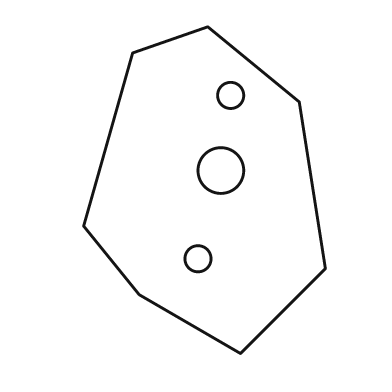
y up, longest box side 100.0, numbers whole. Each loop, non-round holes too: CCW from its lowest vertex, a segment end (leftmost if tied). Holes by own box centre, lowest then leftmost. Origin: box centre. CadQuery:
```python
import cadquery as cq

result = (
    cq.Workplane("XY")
    .moveTo(11.0, -50.0)
    .lineTo(37.0, -24.0)
    .lineTo(29.0, 27.0)
    .lineTo(1.0, 50.0)
    .lineTo(-22.0, 42.0)
    .lineTo(-37.0, -11.0)
    .lineTo(-20.0, -32.0)
    .close()
    .moveTo(-2.0, -21.0)
    .circle(4.0)
    .moveTo(5.0, 6.0)
    .circle(7.0)
    .moveTo(8.0, 29.0)
    .circle(4.0)
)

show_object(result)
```